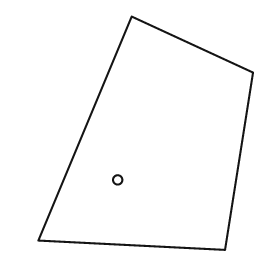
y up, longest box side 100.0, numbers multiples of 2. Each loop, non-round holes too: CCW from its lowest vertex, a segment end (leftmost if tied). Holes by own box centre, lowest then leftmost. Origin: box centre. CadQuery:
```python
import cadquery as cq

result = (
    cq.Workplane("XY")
    .moveTo(34.0, -50.0)
    .lineTo(46.0, 26.0)
    .lineTo(-6.0, 50.0)
    .lineTo(-46.0, -46.0)
    .close()
    .moveTo(-12.0, -20.0)
    .circle(2.0)
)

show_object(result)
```